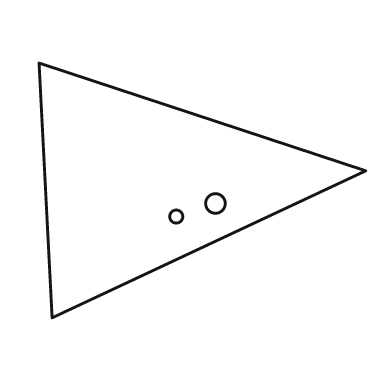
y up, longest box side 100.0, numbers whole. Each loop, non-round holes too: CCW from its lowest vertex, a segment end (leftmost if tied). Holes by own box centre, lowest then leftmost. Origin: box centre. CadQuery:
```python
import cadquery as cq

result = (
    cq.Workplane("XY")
    .moveTo(-46.0, -39.0)
    .lineTo(50.0, 6.0)
    .lineTo(-50.0, 39.0)
    .close()
    .moveTo(-8.0, -8.0)
    .circle(2.0)
    .moveTo(4.0, -4.0)
    .circle(3.0)
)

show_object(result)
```